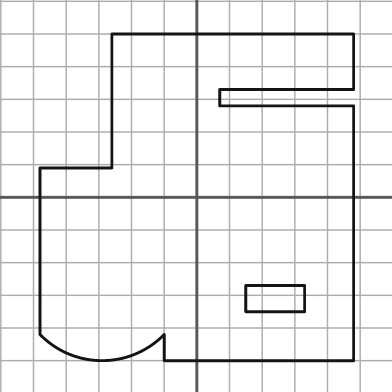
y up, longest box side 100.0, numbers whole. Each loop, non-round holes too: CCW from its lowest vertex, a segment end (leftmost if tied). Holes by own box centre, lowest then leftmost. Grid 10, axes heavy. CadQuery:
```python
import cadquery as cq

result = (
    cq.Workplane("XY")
    .moveTo(-10.0, -50.0)
    .lineTo(48.0, -50.0)
    .lineTo(48.0, 28.0)
    .lineTo(7.0, 28.0)
    .lineTo(7.0, 33.0)
    .lineTo(48.0, 33.0)
    .lineTo(48.0, 50.0)
    .lineTo(-26.0, 50.0)
    .lineTo(-26.0, 9.0)
    .lineTo(-48.0, 9.0)
    .lineTo(-48.0, -42.0)
    .threePointArc((-29.0, -50.0), (-10.0, -42.0))
    .close()
    .moveTo(15.0, -35.0)
    .lineTo(33.0, -35.0)
    .lineTo(33.0, -27.0)
    .lineTo(15.0, -27.0)
    .close()
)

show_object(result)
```